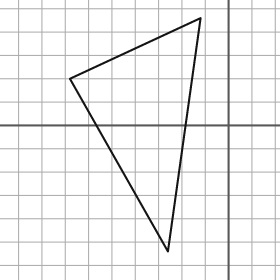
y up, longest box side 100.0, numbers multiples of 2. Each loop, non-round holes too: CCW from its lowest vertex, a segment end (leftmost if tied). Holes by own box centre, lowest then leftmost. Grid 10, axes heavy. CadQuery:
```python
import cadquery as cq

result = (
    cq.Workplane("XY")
    .moveTo(-26.0, -54.0)
    .lineTo(-12.0, 46.0)
    .lineTo(-68.0, 20.0)
    .close()
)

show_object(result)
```